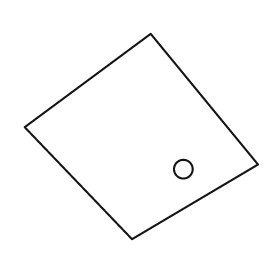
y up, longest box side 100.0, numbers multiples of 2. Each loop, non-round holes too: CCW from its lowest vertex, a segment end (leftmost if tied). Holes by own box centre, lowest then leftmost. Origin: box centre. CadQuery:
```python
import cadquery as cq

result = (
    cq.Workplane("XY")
    .moveTo(-4.0, -44.0)
    .lineTo(50.0, -12.0)
    .lineTo(4.0, 44.0)
    .lineTo(-50.0, 4.0)
    .close()
    .moveTo(18.0, -14.0)
    .circle(4.0)
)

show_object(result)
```